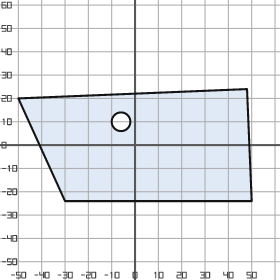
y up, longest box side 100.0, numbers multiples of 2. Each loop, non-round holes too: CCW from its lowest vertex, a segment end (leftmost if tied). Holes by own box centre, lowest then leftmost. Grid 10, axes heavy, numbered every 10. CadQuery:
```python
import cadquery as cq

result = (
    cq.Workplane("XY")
    .moveTo(-30.0, -24.0)
    .lineTo(50.0, -24.0)
    .lineTo(48.0, 24.0)
    .lineTo(-50.0, 20.0)
    .close()
    .moveTo(-6.0, 10.0)
    .circle(4.0)
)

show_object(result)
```